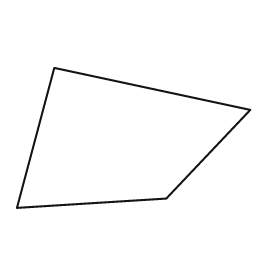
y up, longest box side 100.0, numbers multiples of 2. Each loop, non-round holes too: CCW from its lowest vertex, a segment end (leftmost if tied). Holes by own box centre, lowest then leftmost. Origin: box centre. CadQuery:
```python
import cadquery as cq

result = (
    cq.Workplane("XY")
    .moveTo(-50.0, -30.0)
    .lineTo(14.0, -26.0)
    .lineTo(50.0, 12.0)
    .lineTo(-34.0, 30.0)
    .close()
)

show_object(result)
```